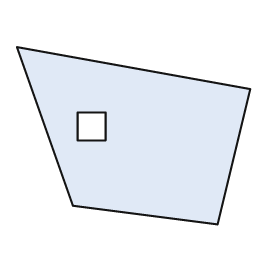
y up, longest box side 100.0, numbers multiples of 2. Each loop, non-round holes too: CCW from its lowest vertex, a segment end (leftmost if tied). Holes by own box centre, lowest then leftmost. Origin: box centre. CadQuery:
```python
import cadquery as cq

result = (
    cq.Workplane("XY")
    .moveTo(36.0, -38.0)
    .lineTo(50.0, 20.0)
    .lineTo(-50.0, 38.0)
    .lineTo(-26.0, -30.0)
    .close()
    .moveTo(-24.0, -2.0)
    .lineTo(-12.0, -2.0)
    .lineTo(-12.0, 10.0)
    .lineTo(-24.0, 10.0)
    .close()
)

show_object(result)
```